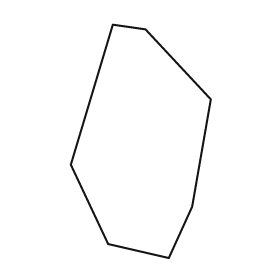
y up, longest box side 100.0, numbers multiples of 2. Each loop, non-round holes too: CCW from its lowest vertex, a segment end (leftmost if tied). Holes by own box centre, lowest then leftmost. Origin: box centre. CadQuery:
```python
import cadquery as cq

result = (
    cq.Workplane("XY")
    .moveTo(12.0, -50.0)
    .lineTo(22.0, -28.0)
    .lineTo(30.0, 18.0)
    .lineTo(2.0, 48.0)
    .lineTo(-12.0, 50.0)
    .lineTo(-30.0, -10.0)
    .lineTo(-14.0, -44.0)
    .close()
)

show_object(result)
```